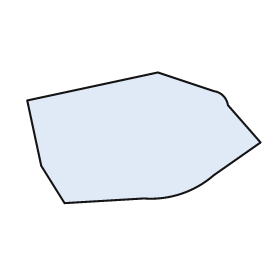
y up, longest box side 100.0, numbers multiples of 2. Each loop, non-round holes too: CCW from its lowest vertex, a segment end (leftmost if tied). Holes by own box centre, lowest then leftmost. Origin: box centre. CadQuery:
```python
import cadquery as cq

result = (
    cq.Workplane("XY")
    .moveTo(-34.0, -28.0)
    .lineTo(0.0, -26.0)
    .threePointArc((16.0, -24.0), (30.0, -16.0))
    .lineTo(50.0, -2.0)
    .lineTo(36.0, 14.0)
    .threePointArc((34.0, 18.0), (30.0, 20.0))
    .lineTo(6.0, 28.0)
    .lineTo(-50.0, 16.0)
    .lineTo(-44.0, -12.0)
    .close()
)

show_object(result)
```